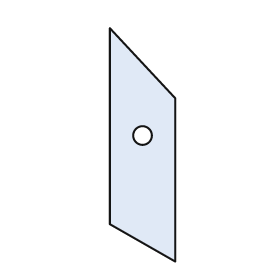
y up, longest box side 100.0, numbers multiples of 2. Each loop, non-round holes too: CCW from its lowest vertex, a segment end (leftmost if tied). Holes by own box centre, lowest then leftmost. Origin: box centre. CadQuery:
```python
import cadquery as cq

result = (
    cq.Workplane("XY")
    .moveTo(14.0, -50.0)
    .lineTo(14.0, 20.0)
    .lineTo(-14.0, 50.0)
    .lineTo(-14.0, -34.0)
    .close()
    .moveTo(0.0, 4.0)
    .circle(4.0)
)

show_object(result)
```